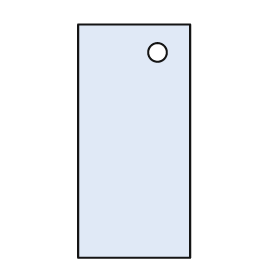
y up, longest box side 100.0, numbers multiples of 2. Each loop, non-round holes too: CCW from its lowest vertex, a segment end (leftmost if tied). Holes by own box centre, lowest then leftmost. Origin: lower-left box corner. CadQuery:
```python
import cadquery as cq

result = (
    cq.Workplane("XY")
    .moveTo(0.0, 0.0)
    .lineTo(48.0, 0.0)
    .lineTo(48.0, 100.0)
    .lineTo(0.0, 100.0)
    .close()
    .moveTo(34.0, 88.0)
    .circle(4.0)
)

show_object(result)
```